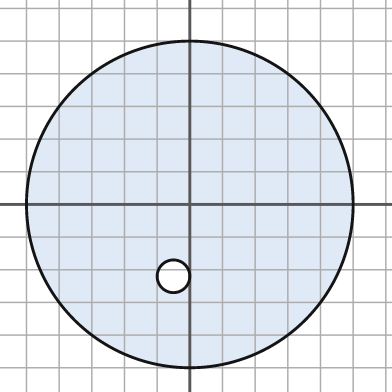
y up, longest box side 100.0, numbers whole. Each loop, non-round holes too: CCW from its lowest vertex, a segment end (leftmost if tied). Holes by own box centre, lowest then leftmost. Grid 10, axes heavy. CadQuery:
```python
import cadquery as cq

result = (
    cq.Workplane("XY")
    .moveTo(0.0, 0.0)
    .circle(50.0)
    .moveTo(-5.0, -22.0)
    .circle(5.0)
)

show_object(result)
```